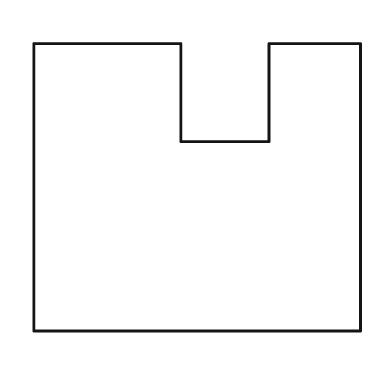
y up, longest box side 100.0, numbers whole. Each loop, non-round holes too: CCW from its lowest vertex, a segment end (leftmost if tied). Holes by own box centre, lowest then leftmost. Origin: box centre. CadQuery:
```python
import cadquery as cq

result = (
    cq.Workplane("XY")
    .moveTo(-50.0, -44.0)
    .lineTo(50.0, -44.0)
    .lineTo(50.0, 44.0)
    .lineTo(22.0, 44.0)
    .lineTo(22.0, 14.0)
    .lineTo(-5.0, 14.0)
    .lineTo(-5.0, 44.0)
    .lineTo(-50.0, 44.0)
    .close()
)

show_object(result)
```